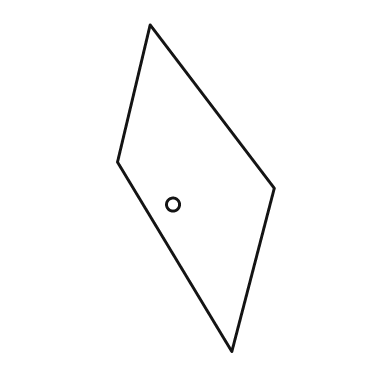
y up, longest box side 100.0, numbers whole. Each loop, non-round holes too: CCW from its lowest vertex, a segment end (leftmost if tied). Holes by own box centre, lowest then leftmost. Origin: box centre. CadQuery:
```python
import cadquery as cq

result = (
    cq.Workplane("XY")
    .moveTo(11.0, -50.0)
    .lineTo(24.0, 0.0)
    .lineTo(-14.0, 50.0)
    .lineTo(-24.0, 8.0)
    .close()
    .moveTo(-7.0, -5.0)
    .circle(2.0)
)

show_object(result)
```